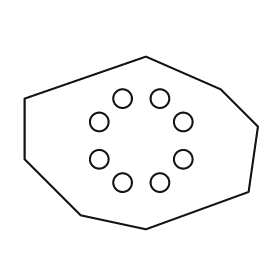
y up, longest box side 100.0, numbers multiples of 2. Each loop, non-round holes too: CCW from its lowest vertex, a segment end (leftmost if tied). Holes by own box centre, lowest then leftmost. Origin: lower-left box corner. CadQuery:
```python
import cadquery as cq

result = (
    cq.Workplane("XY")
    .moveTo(52.0, 0.0)
    .lineTo(96.0, 16.0)
    .lineTo(100.0, 44.0)
    .lineTo(84.0, 60.0)
    .lineTo(52.0, 74.0)
    .lineTo(0.0, 56.0)
    .lineTo(0.0, 30.0)
    .lineTo(24.0, 6.0)
    .close()
    .moveTo(42.0, 20.0)
    .circle(4.0)
    .moveTo(58.0, 20.0)
    .circle(4.0)
    .moveTo(32.0, 30.0)
    .circle(4.0)
    .moveTo(68.0, 30.0)
    .circle(4.0)
    .moveTo(32.0, 46.0)
    .circle(4.0)
    .moveTo(68.0, 46.0)
    .circle(4.0)
    .moveTo(42.0, 56.0)
    .circle(4.0)
    .moveTo(58.0, 56.0)
    .circle(4.0)
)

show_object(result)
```